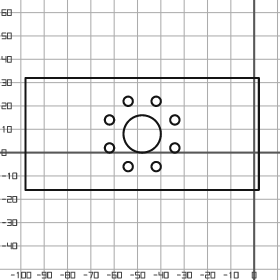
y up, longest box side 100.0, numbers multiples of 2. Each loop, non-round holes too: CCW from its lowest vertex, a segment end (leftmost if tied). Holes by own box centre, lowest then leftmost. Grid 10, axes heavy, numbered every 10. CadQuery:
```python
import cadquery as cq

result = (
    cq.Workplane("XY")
    .moveTo(-98.0, -16.0)
    .lineTo(2.0, -16.0)
    .lineTo(2.0, 32.0)
    .lineTo(-98.0, 32.0)
    .close()
    .moveTo(-54.0, -6.0)
    .circle(2.0)
    .moveTo(-42.0, -6.0)
    .circle(2.0)
    .moveTo(-62.0, 2.0)
    .circle(2.0)
    .moveTo(-34.0, 2.0)
    .circle(2.0)
    .moveTo(-48.0, 8.0)
    .circle(8.0)
    .moveTo(-62.0, 14.0)
    .circle(2.0)
    .moveTo(-34.0, 14.0)
    .circle(2.0)
    .moveTo(-54.0, 22.0)
    .circle(2.0)
    .moveTo(-42.0, 22.0)
    .circle(2.0)
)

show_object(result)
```